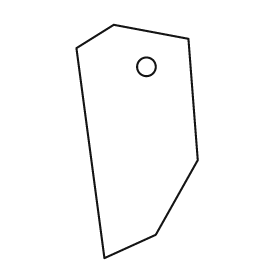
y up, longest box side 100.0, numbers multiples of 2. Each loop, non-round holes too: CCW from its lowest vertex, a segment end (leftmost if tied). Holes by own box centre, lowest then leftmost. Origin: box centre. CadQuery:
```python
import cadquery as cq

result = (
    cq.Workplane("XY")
    .moveTo(-14.0, -50.0)
    .lineTo(8.0, -40.0)
    .lineTo(26.0, -8.0)
    .lineTo(22.0, 44.0)
    .lineTo(-10.0, 50.0)
    .lineTo(-26.0, 40.0)
    .close()
    .moveTo(4.0, 32.0)
    .circle(4.0)
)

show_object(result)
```